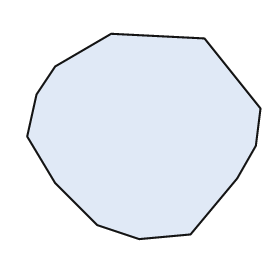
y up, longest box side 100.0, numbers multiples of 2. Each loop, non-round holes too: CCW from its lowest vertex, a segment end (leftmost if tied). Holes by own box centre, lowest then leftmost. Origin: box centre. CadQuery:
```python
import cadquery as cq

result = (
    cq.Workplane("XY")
    .moveTo(-2.0, -44.0)
    .lineTo(20.0, -42.0)
    .lineTo(40.0, -18.0)
    .lineTo(48.0, -4.0)
    .lineTo(50.0, 12.0)
    .lineTo(26.0, 42.0)
    .lineTo(-14.0, 44.0)
    .lineTo(-38.0, 30.0)
    .lineTo(-46.0, 18.0)
    .lineTo(-50.0, 0.0)
    .lineTo(-38.0, -20.0)
    .lineTo(-20.0, -38.0)
    .close()
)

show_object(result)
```